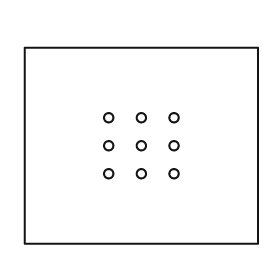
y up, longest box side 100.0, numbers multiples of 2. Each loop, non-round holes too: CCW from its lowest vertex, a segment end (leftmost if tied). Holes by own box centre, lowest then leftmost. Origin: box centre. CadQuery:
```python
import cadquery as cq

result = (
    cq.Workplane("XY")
    .moveTo(-50.0, -42.0)
    .lineTo(50.0, -42.0)
    .lineTo(50.0, 42.0)
    .lineTo(-50.0, 42.0)
    .close()
    .moveTo(-14.0, -12.0)
    .circle(2.0)
    .moveTo(0.0, -12.0)
    .circle(2.0)
    .moveTo(14.0, -12.0)
    .circle(2.0)
    .moveTo(-14.0, 0.0)
    .circle(2.0)
    .moveTo(0.0, 0.0)
    .circle(2.0)
    .moveTo(14.0, 0.0)
    .circle(2.0)
    .moveTo(-14.0, 12.0)
    .circle(2.0)
    .moveTo(0.0, 12.0)
    .circle(2.0)
    .moveTo(14.0, 12.0)
    .circle(2.0)
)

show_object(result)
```